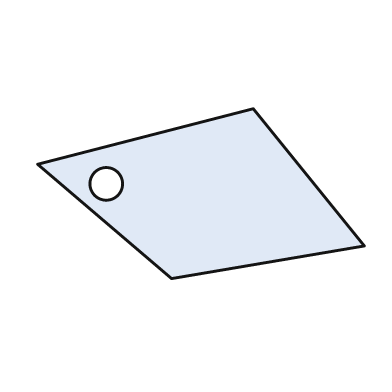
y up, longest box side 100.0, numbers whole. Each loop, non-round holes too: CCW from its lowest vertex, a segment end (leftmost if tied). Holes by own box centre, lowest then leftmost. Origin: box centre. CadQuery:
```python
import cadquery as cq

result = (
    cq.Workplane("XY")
    .moveTo(-9.0, -26.0)
    .lineTo(50.0, -16.0)
    .lineTo(16.0, 26.0)
    .lineTo(-50.0, 9.0)
    .close()
    .moveTo(-29.0, 3.0)
    .circle(5.0)
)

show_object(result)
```